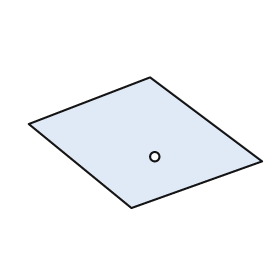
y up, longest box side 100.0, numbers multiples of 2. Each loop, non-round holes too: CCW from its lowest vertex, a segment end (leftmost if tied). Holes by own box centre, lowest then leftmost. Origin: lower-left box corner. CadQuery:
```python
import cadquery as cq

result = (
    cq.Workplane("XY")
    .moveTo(44.0, 0.0)
    .lineTo(100.0, 20.0)
    .lineTo(52.0, 56.0)
    .lineTo(0.0, 36.0)
    .close()
    .moveTo(54.0, 22.0)
    .circle(2.0)
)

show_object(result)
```